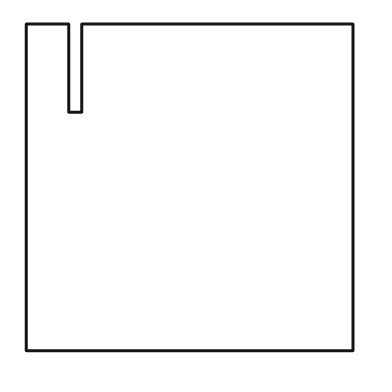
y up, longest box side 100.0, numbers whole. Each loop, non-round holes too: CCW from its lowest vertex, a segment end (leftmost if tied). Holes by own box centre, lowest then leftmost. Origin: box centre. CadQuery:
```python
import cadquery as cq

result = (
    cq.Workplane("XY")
    .moveTo(-50.0, -50.0)
    .lineTo(50.0, -50.0)
    .lineTo(50.0, 50.0)
    .lineTo(-33.0, 50.0)
    .lineTo(-33.0, 23.0)
    .lineTo(-37.0, 23.0)
    .lineTo(-37.0, 50.0)
    .lineTo(-50.0, 50.0)
    .close()
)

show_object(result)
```